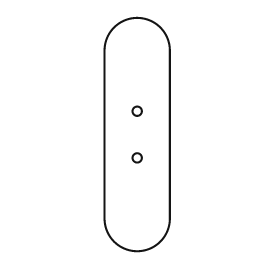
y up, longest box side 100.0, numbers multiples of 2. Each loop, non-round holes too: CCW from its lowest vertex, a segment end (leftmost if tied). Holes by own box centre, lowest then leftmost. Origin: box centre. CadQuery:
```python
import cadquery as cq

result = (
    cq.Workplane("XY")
    .moveTo(-14.0, -36.0)
    .threePointArc((0.0, -50.0), (14.0, -36.0))
    .lineTo(14.0, 36.0)
    .threePointArc((0.0, 50.0), (-14.0, 36.0))
    .close()
    .moveTo(0.0, -10.0)
    .circle(2.0)
    .moveTo(0.0, 10.0)
    .circle(2.0)
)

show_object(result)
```